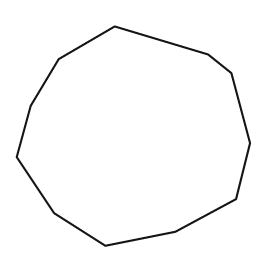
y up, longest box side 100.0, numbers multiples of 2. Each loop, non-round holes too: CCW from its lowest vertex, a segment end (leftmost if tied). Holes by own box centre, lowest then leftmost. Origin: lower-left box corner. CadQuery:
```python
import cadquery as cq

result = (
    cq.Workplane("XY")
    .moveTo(38.0, 0.0)
    .lineTo(68.0, 6.0)
    .lineTo(94.0, 20.0)
    .lineTo(100.0, 44.0)
    .lineTo(92.0, 74.0)
    .lineTo(82.0, 82.0)
    .lineTo(42.0, 94.0)
    .lineTo(18.0, 80.0)
    .lineTo(6.0, 60.0)
    .lineTo(0.0, 38.0)
    .lineTo(16.0, 14.0)
    .close()
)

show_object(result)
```